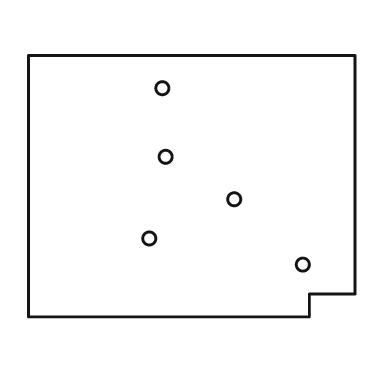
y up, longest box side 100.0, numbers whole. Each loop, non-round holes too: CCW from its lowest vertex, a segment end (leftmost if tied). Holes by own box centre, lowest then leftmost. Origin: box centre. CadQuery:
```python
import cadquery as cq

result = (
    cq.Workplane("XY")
    .moveTo(-50.0, -40.0)
    .lineTo(36.0, -40.0)
    .lineTo(36.0, -33.0)
    .lineTo(50.0, -33.0)
    .lineTo(50.0, 40.0)
    .lineTo(-50.0, 40.0)
    .close()
    .moveTo(34.0, -24.0)
    .circle(2.0)
    .moveTo(-13.0, -16.0)
    .circle(2.0)
    .moveTo(13.0, -4.0)
    .circle(2.0)
    .moveTo(-8.0, 9.0)
    .circle(2.0)
    .moveTo(-9.0, 30.0)
    .circle(2.0)
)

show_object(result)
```